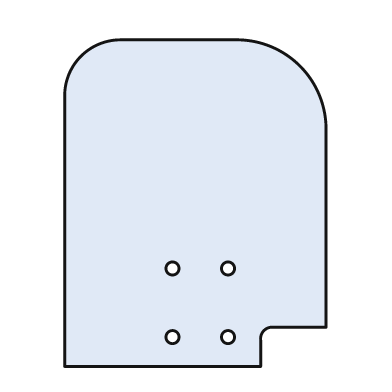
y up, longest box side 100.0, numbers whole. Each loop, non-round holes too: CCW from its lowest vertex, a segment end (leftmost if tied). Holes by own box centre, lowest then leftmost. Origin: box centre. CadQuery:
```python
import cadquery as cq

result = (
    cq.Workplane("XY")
    .moveTo(-40.0, -50.0)
    .lineTo(20.0, -50.0)
    .lineTo(20.0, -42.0)
    .threePointArc((21.0, -39.0), (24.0, -38.0))
    .lineTo(40.0, -38.0)
    .lineTo(40.0, 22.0)
    .threePointArc((32.0, 42.0), (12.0, 50.0))
    .lineTo(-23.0, 50.0)
    .threePointArc((-35.0, 45.0), (-40.0, 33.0))
    .close()
    .moveTo(-7.0, -41.0)
    .circle(2.0)
    .moveTo(10.0, -41.0)
    .circle(2.0)
    .moveTo(-7.0, -20.0)
    .circle(2.0)
    .moveTo(10.0, -20.0)
    .circle(2.0)
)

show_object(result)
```